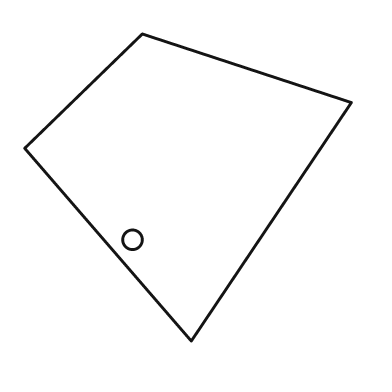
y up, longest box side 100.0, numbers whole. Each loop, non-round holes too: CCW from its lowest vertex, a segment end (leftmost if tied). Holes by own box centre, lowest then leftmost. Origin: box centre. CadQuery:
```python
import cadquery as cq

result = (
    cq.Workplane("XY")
    .moveTo(1.0, -47.0)
    .lineTo(50.0, 26.0)
    .lineTo(-14.0, 47.0)
    .lineTo(-50.0, 12.0)
    .close()
    .moveTo(-17.0, -16.0)
    .circle(3.0)
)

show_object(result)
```